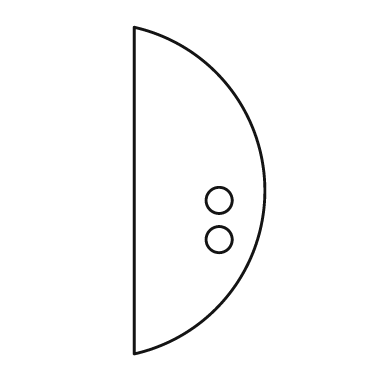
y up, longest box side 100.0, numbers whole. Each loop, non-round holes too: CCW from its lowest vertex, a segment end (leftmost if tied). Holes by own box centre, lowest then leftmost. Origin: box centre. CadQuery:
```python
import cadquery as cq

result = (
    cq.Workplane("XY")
    .moveTo(-20.0, -50.0)
    .threePointArc((20.0, 0.0), (-20.0, 50.0))
    .close()
    .moveTo(6.0, -15.0)
    .circle(4.0)
    .moveTo(6.0, -3.0)
    .circle(4.0)
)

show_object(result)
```